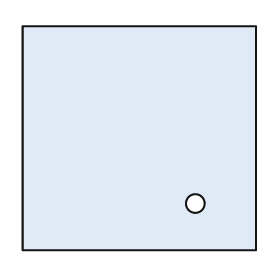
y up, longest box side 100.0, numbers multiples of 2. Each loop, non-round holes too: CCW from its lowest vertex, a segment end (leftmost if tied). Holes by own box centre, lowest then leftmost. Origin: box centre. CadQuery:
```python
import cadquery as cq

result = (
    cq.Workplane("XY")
    .moveTo(-50.0, -48.0)
    .lineTo(50.0, -48.0)
    .lineTo(50.0, 48.0)
    .lineTo(-50.0, 48.0)
    .close()
    .moveTo(24.0, -28.0)
    .circle(4.0)
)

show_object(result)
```